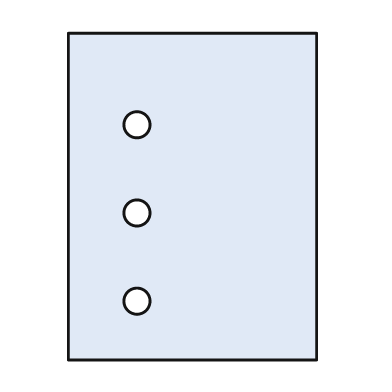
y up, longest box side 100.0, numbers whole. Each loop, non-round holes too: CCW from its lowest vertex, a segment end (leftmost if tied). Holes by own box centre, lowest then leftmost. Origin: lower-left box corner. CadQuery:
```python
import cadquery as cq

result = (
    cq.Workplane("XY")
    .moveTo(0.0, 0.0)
    .lineTo(76.0, 0.0)
    .lineTo(76.0, 100.0)
    .lineTo(0.0, 100.0)
    .close()
    .moveTo(21.0, 18.0)
    .circle(4.0)
    .moveTo(21.0, 45.0)
    .circle(4.0)
    .moveTo(21.0, 72.0)
    .circle(4.0)
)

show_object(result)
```